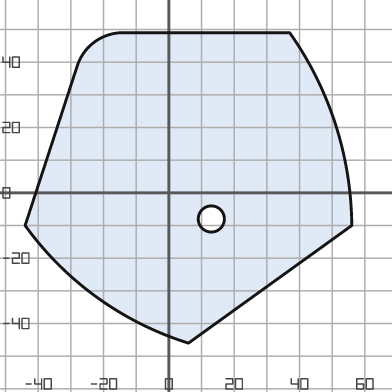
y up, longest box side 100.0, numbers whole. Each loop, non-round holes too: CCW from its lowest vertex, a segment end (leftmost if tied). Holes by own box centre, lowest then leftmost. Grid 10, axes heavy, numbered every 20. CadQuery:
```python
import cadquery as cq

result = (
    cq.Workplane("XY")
    .moveTo(6.0, -46.0)
    .lineTo(56.0, -10.0)
    .threePointArc((51.0, 21.0), (37.0, 49.0))
    .lineTo(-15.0, 49.0)
    .threePointArc((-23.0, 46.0), (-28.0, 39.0))
    .lineTo(-44.0, -10.0)
    .threePointArc((-22.0, -32.0), (6.0, -46.0))
    .close()
    .moveTo(13.0, -8.0)
    .circle(4.0)
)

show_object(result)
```